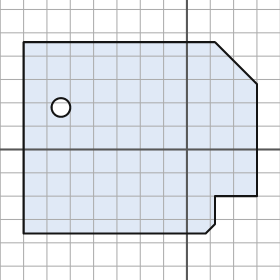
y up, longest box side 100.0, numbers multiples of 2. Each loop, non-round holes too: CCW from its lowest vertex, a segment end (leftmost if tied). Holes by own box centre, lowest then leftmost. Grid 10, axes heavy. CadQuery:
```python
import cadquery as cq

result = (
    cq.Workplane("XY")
    .moveTo(-70.0, -36.0)
    .lineTo(8.0, -36.0)
    .lineTo(12.0, -32.0)
    .lineTo(12.0, -20.0)
    .lineTo(30.0, -20.0)
    .lineTo(30.0, 28.0)
    .lineTo(12.0, 46.0)
    .lineTo(-70.0, 46.0)
    .close()
    .moveTo(-54.0, 18.0)
    .circle(4.0)
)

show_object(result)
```